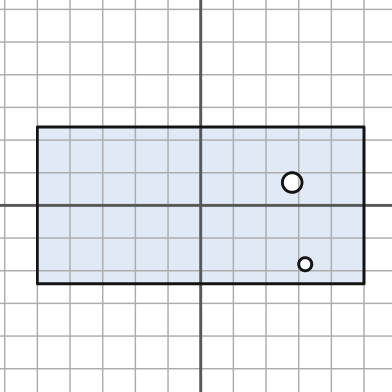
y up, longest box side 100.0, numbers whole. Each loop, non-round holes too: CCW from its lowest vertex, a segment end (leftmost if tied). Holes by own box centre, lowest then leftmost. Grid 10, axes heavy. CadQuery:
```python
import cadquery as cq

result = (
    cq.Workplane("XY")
    .moveTo(-50.0, -24.0)
    .lineTo(50.0, -24.0)
    .lineTo(50.0, 24.0)
    .lineTo(-50.0, 24.0)
    .close()
    .moveTo(32.0, -18.0)
    .circle(2.0)
    .moveTo(28.0, 7.0)
    .circle(3.0)
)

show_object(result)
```